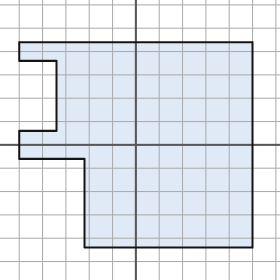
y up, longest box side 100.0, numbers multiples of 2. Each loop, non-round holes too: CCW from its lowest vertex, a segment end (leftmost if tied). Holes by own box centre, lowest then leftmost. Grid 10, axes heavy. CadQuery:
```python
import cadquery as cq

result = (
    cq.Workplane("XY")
    .moveTo(-22.0, -44.0)
    .lineTo(50.0, -44.0)
    .lineTo(50.0, 44.0)
    .lineTo(-50.0, 44.0)
    .lineTo(-50.0, 36.0)
    .lineTo(-34.0, 36.0)
    .lineTo(-34.0, 6.0)
    .lineTo(-50.0, 6.0)
    .lineTo(-50.0, -6.0)
    .lineTo(-22.0, -6.0)
    .close()
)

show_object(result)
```